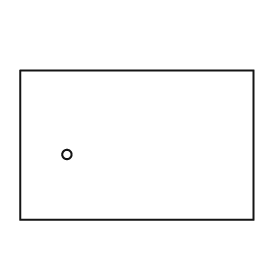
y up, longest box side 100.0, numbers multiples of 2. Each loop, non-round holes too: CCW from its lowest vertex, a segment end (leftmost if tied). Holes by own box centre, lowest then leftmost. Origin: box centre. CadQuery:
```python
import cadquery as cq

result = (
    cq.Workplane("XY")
    .moveTo(-50.0, -32.0)
    .lineTo(50.0, -32.0)
    .lineTo(50.0, 32.0)
    .lineTo(-50.0, 32.0)
    .close()
    .moveTo(-30.0, -4.0)
    .circle(2.0)
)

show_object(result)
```